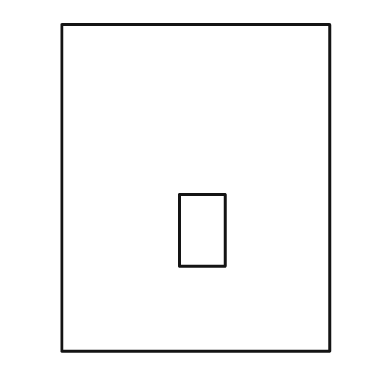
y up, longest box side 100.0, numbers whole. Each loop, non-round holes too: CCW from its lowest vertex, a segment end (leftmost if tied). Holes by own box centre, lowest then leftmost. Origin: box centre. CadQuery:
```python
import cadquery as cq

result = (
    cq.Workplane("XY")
    .moveTo(-41.0, -50.0)
    .lineTo(41.0, -50.0)
    .lineTo(41.0, 50.0)
    .lineTo(-41.0, 50.0)
    .close()
    .moveTo(-5.0, -24.0)
    .lineTo(9.0, -24.0)
    .lineTo(9.0, -2.0)
    .lineTo(-5.0, -2.0)
    .close()
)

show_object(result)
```